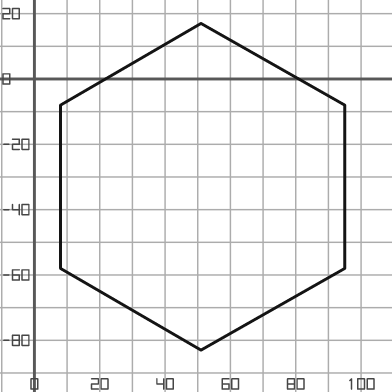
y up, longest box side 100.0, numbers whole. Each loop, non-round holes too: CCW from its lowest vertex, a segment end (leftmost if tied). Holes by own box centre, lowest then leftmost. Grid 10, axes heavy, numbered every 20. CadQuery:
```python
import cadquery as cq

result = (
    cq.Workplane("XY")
    .moveTo(51.0, -83.0)
    .lineTo(95.0, -58.0)
    .lineTo(95.0, -8.0)
    .lineTo(51.0, 17.0)
    .lineTo(8.0, -8.0)
    .lineTo(8.0, -58.0)
    .close()
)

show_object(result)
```